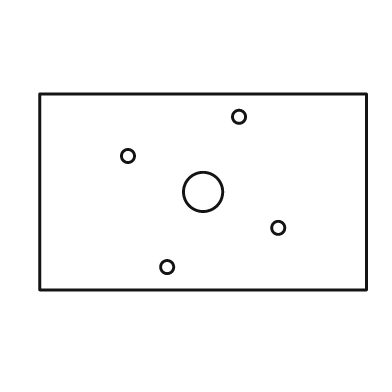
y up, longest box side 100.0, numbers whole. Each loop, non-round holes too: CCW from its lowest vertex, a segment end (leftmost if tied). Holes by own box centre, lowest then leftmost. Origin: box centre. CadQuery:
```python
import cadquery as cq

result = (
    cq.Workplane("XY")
    .moveTo(-50.0, -30.0)
    .lineTo(50.0, -30.0)
    .lineTo(50.0, 30.0)
    .lineTo(-50.0, 30.0)
    .close()
    .moveTo(-11.0, -23.0)
    .circle(2.0)
    .moveTo(23.0, -11.0)
    .circle(2.0)
    .moveTo(0.0, 0.0)
    .circle(6.0)
    .moveTo(-23.0, 11.0)
    .circle(2.0)
    .moveTo(11.0, 23.0)
    .circle(2.0)
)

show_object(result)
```